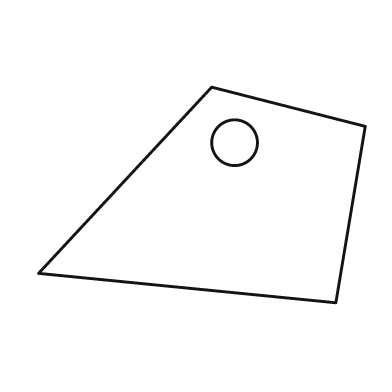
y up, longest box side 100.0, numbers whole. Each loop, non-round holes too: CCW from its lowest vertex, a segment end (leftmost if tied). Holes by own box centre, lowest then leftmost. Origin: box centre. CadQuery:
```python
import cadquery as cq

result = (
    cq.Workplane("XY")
    .moveTo(41.0, -33.0)
    .lineTo(50.0, 21.0)
    .lineTo(3.0, 33.0)
    .lineTo(-50.0, -24.0)
    .close()
    .moveTo(10.0, 16.0)
    .circle(7.0)
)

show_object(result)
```